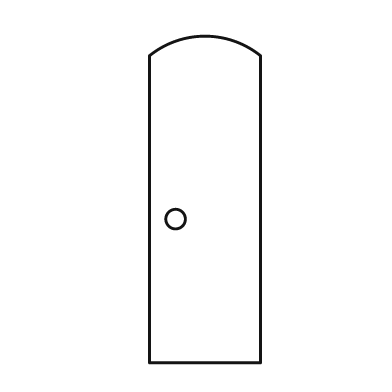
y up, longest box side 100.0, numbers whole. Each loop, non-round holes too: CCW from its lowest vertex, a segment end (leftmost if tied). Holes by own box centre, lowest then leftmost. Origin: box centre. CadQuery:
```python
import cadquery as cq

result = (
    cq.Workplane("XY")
    .moveTo(-17.0, -50.0)
    .lineTo(17.0, -50.0)
    .lineTo(17.0, 44.0)
    .threePointArc((0.0, 50.0), (-17.0, 44.0))
    .close()
    .moveTo(-9.0, -6.0)
    .circle(3.0)
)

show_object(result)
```